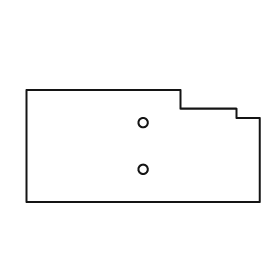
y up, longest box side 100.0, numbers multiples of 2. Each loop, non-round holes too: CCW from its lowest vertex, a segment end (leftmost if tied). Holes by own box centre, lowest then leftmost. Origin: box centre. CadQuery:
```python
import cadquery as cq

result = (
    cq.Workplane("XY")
    .moveTo(-50.0, -24.0)
    .lineTo(50.0, -24.0)
    .lineTo(50.0, 12.0)
    .lineTo(40.0, 12.0)
    .lineTo(40.0, 16.0)
    .lineTo(16.0, 16.0)
    .lineTo(16.0, 24.0)
    .lineTo(-50.0, 24.0)
    .close()
    .moveTo(0.0, -10.0)
    .circle(2.0)
    .moveTo(0.0, 10.0)
    .circle(2.0)
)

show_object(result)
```